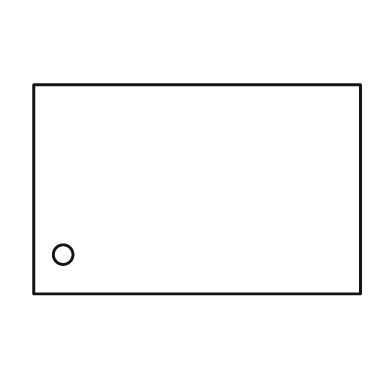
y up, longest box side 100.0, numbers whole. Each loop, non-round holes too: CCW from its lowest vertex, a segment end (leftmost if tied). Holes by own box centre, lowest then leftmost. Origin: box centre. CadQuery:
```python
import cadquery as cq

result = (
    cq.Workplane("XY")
    .moveTo(-50.0, -32.0)
    .lineTo(50.0, -32.0)
    .lineTo(50.0, 32.0)
    .lineTo(-50.0, 32.0)
    .close()
    .moveTo(-41.0, -20.0)
    .circle(3.0)
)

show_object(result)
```